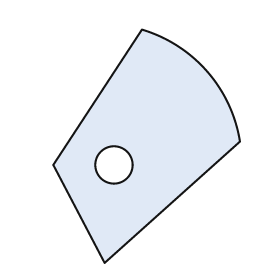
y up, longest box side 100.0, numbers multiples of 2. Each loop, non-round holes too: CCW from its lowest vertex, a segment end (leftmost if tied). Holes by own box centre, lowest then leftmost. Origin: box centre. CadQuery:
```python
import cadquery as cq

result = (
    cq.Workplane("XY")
    .moveTo(-18.0, -50.0)
    .lineTo(40.0, 2.0)
    .threePointArc((26.0, 32.0), (-2.0, 50.0))
    .lineTo(-40.0, -8.0)
    .close()
    .moveTo(-14.0, -8.0)
    .circle(8.0)
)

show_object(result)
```